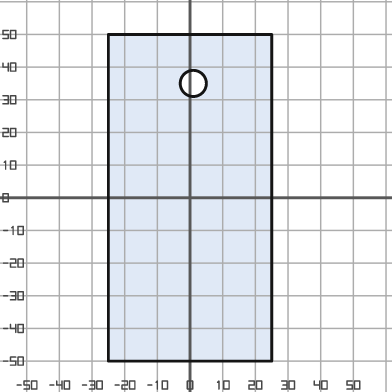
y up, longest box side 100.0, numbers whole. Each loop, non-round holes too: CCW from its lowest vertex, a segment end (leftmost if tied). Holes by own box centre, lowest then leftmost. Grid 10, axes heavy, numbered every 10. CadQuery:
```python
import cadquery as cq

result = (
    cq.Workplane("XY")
    .moveTo(-25.0, -50.0)
    .lineTo(25.0, -50.0)
    .lineTo(25.0, 50.0)
    .lineTo(-25.0, 50.0)
    .close()
    .moveTo(1.0, 35.0)
    .circle(4.0)
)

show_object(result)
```